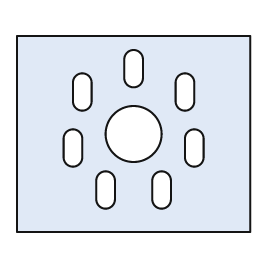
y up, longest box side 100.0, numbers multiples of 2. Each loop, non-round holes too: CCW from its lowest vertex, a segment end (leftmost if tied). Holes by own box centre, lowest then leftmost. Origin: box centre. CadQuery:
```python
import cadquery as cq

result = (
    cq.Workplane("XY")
    .moveTo(-50.0, -42.0)
    .lineTo(50.0, -42.0)
    .lineTo(50.0, 42.0)
    .lineTo(-50.0, 42.0)
    .close()
    .moveTo(-16.0, -28.0)
    .threePointArc((-12.0, -32.0), (-8.0, -28.0))
    .lineTo(-8.0, -20.0)
    .threePointArc((-12.0, -16.0), (-16.0, -20.0))
    .close()
    .moveTo(8.0, -28.0)
    .threePointArc((12.0, -32.0), (16.0, -28.0))
    .lineTo(16.0, -20.0)
    .threePointArc((12.0, -16.0), (8.0, -20.0))
    .close()
    .moveTo(-30.0, -10.0)
    .threePointArc((-26.0, -14.0), (-22.0, -10.0))
    .lineTo(-22.0, -2.0)
    .threePointArc((-26.0, 2.0), (-30.0, -2.0))
    .close()
    .moveTo(22.0, -10.0)
    .threePointArc((26.0, -14.0), (30.0, -10.0))
    .lineTo(30.0, -2.0)
    .threePointArc((26.0, 2.0), (22.0, -2.0))
    .close()
    .moveTo(0.0, 0.0)
    .circle(12.0)
    .moveTo(-26.0, 14.0)
    .threePointArc((-22.0, 10.0), (-18.0, 14.0))
    .lineTo(-18.0, 22.0)
    .threePointArc((-22.0, 26.0), (-26.0, 22.0))
    .close()
    .moveTo(18.0, 14.0)
    .threePointArc((22.0, 10.0), (26.0, 14.0))
    .lineTo(26.0, 22.0)
    .threePointArc((22.0, 26.0), (18.0, 22.0))
    .close()
    .moveTo(-4.0, 24.0)
    .threePointArc((0.0, 20.0), (4.0, 24.0))
    .lineTo(4.0, 32.0)
    .threePointArc((0.0, 36.0), (-4.0, 32.0))
    .close()
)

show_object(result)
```